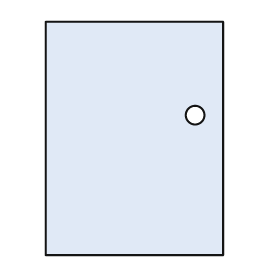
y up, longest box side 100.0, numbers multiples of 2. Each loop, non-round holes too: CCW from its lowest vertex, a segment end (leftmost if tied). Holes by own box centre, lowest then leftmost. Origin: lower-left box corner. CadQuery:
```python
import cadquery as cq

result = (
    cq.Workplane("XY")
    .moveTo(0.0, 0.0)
    .lineTo(76.0, 0.0)
    .lineTo(76.0, 100.0)
    .lineTo(0.0, 100.0)
    .close()
    .moveTo(64.0, 60.0)
    .circle(4.0)
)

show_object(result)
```